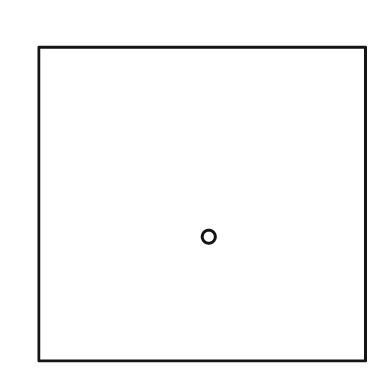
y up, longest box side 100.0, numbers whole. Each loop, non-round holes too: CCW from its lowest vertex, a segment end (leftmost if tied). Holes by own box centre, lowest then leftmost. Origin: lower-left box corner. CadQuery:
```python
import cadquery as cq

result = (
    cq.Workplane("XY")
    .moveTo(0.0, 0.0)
    .lineTo(100.0, 0.0)
    .lineTo(100.0, 96.0)
    .lineTo(0.0, 96.0)
    .close()
    .moveTo(52.0, 38.0)
    .circle(2.0)
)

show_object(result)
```